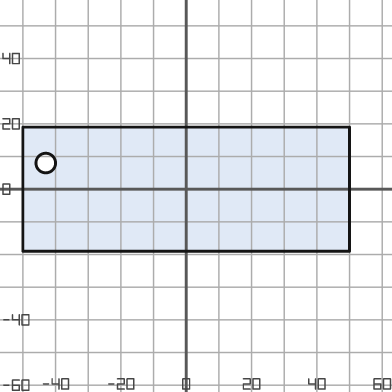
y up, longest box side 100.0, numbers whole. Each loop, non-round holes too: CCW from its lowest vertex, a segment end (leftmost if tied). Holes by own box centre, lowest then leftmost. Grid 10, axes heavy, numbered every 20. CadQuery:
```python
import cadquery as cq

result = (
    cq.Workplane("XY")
    .moveTo(-50.0, -19.0)
    .lineTo(50.0, -19.0)
    .lineTo(50.0, 19.0)
    .lineTo(-50.0, 19.0)
    .close()
    .moveTo(-43.0, 8.0)
    .circle(3.0)
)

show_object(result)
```